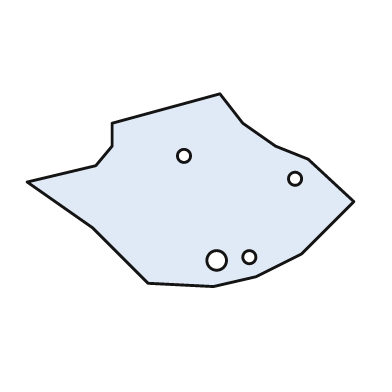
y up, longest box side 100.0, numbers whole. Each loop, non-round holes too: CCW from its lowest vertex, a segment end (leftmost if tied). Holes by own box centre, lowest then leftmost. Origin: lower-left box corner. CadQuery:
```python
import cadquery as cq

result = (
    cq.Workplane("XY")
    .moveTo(57.0, 0.0)
    .lineTo(70.0, 3.0)
    .lineTo(84.0, 10.0)
    .lineTo(100.0, 26.0)
    .lineTo(86.0, 39.0)
    .lineTo(76.0, 43.0)
    .lineTo(66.0, 50.0)
    .lineTo(59.0, 59.0)
    .lineTo(26.0, 50.0)
    .lineTo(26.0, 43.0)
    .lineTo(21.0, 37.0)
    .lineTo(0.0, 32.0)
    .lineTo(20.0, 18.0)
    .lineTo(37.0, 1.0)
    .close()
    .moveTo(58.0, 8.0)
    .circle(3.0)
    .moveTo(68.0, 9.0)
    .circle(2.0)
    .moveTo(82.0, 33.0)
    .circle(2.0)
    .moveTo(48.0, 40.0)
    .circle(2.0)
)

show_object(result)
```